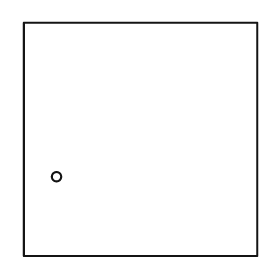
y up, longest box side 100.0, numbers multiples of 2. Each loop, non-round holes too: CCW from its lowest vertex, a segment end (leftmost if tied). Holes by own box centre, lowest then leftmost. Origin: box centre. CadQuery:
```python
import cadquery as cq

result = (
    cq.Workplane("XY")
    .moveTo(-50.0, -50.0)
    .lineTo(50.0, -50.0)
    .lineTo(50.0, 50.0)
    .lineTo(-50.0, 50.0)
    .close()
    .moveTo(-36.0, -16.0)
    .circle(2.0)
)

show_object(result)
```